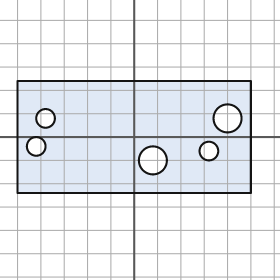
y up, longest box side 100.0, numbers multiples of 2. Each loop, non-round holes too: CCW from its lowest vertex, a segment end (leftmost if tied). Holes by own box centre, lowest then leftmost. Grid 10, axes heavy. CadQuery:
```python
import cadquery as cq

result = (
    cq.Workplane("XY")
    .moveTo(-50.0, -24.0)
    .lineTo(50.0, -24.0)
    .lineTo(50.0, 24.0)
    .lineTo(-50.0, 24.0)
    .close()
    .moveTo(8.0, -10.0)
    .circle(6.0)
    .moveTo(32.0, -6.0)
    .circle(4.0)
    .moveTo(-42.0, -4.0)
    .circle(4.0)
    .moveTo(-38.0, 8.0)
    .circle(4.0)
    .moveTo(40.0, 8.0)
    .circle(6.0)
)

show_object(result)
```